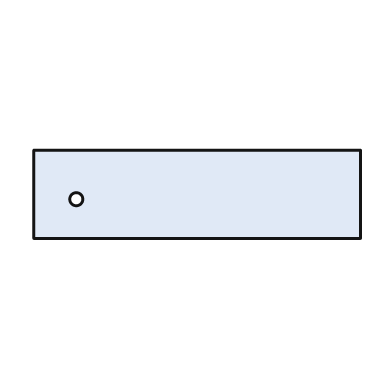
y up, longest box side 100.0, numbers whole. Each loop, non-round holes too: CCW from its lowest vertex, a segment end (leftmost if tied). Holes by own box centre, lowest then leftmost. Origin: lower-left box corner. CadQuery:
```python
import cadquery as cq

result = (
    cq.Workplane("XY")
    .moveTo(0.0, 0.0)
    .lineTo(100.0, 0.0)
    .lineTo(100.0, 27.0)
    .lineTo(0.0, 27.0)
    .close()
    .moveTo(13.0, 12.0)
    .circle(2.0)
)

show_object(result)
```